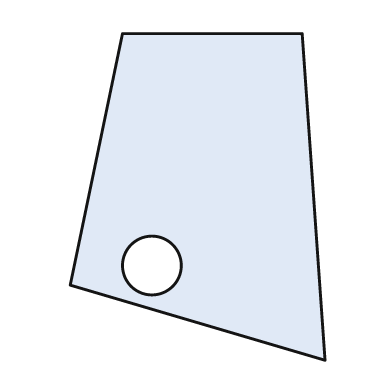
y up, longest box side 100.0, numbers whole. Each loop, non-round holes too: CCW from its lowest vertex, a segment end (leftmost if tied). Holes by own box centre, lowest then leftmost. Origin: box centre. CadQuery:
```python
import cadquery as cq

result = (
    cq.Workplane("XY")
    .moveTo(39.0, -50.0)
    .lineTo(32.0, 50.0)
    .lineTo(-23.0, 50.0)
    .lineTo(-39.0, -27.0)
    .close()
    .moveTo(-14.0, -21.0)
    .circle(9.0)
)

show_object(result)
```